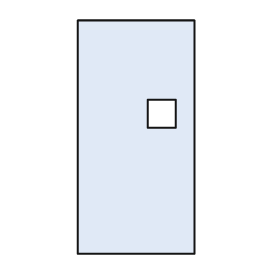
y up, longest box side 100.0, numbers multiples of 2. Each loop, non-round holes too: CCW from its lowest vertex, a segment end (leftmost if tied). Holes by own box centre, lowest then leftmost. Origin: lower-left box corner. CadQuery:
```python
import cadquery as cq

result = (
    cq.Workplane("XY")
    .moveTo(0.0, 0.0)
    .lineTo(50.0, 0.0)
    .lineTo(50.0, 100.0)
    .lineTo(0.0, 100.0)
    .close()
    .moveTo(30.0, 54.0)
    .lineTo(42.0, 54.0)
    .lineTo(42.0, 66.0)
    .lineTo(30.0, 66.0)
    .close()
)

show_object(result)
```